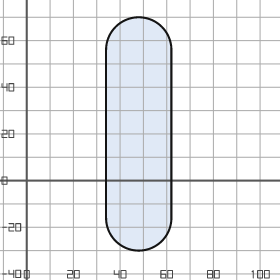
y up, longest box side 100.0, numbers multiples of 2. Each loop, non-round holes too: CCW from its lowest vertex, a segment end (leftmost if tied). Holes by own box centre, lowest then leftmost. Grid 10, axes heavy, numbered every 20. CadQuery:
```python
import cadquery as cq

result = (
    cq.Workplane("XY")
    .moveTo(34.0, -16.0)
    .threePointArc((48.0, -30.0), (62.0, -16.0))
    .lineTo(62.0, 56.0)
    .threePointArc((48.0, 70.0), (34.0, 56.0))
    .close()
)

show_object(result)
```